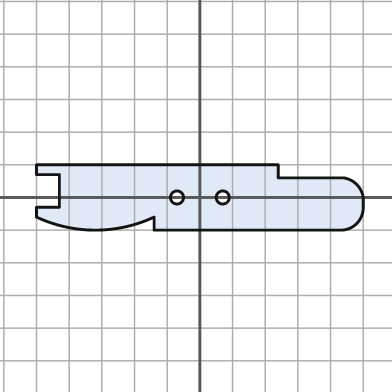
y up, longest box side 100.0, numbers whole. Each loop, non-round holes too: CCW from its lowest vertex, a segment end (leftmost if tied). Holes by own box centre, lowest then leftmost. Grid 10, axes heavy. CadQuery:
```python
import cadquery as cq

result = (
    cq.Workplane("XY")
    .moveTo(-14.0, -10.0)
    .lineTo(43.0, -10.0)
    .threePointArc((48.0, -8.0), (50.0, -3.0))
    .lineTo(50.0, 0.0)
    .threePointArc((48.0, 4.0), (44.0, 6.0))
    .lineTo(24.0, 6.0)
    .lineTo(24.0, 10.0)
    .lineTo(-50.0, 10.0)
    .lineTo(-50.0, 7.0)
    .lineTo(-43.0, 7.0)
    .lineTo(-43.0, -3.0)
    .lineTo(-50.0, -3.0)
    .lineTo(-50.0, -6.0)
    .threePointArc((-32.0, -10.0), (-14.0, -6.0))
    .close()
    .moveTo(-7.0, 0.0)
    .circle(2.0)
    .moveTo(7.0, 0.0)
    .circle(2.0)
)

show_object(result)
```